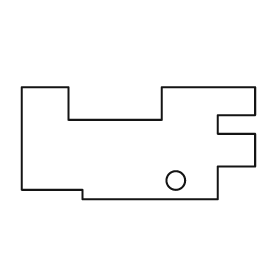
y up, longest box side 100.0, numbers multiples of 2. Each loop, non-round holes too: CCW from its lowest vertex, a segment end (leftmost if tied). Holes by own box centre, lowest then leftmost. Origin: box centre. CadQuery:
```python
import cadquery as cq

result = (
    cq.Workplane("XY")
    .moveTo(-24.0, -24.0)
    .lineTo(34.0, -24.0)
    .lineTo(34.0, -10.0)
    .lineTo(50.0, -10.0)
    .lineTo(50.0, 4.0)
    .lineTo(34.0, 4.0)
    .lineTo(34.0, 12.0)
    .lineTo(50.0, 12.0)
    .lineTo(50.0, 24.0)
    .lineTo(10.0, 24.0)
    .lineTo(10.0, 10.0)
    .lineTo(-30.0, 10.0)
    .lineTo(-30.0, 24.0)
    .lineTo(-50.0, 24.0)
    .lineTo(-50.0, -20.0)
    .lineTo(-24.0, -20.0)
    .close()
    .moveTo(16.0, -16.0)
    .circle(4.0)
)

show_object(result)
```